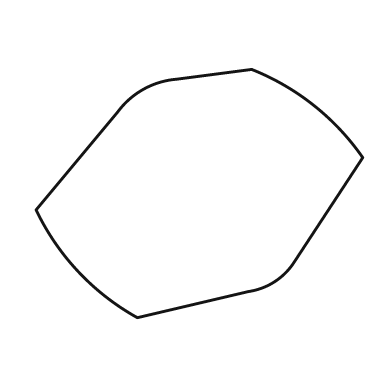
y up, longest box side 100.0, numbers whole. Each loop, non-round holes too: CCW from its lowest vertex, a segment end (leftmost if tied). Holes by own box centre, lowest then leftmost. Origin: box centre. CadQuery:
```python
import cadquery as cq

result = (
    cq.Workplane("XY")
    .moveTo(-19.0, -38.0)
    .lineTo(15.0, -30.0)
    .threePointArc((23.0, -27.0), (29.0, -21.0))
    .lineTo(50.0, 11.0)
    .threePointArc((35.0, 27.0), (16.0, 38.0))
    .lineTo(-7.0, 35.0)
    .threePointArc((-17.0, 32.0), (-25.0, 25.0))
    .lineTo(-50.0, -5.0)
    .threePointArc((-37.0, -24.0), (-19.0, -38.0))
    .close()
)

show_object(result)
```